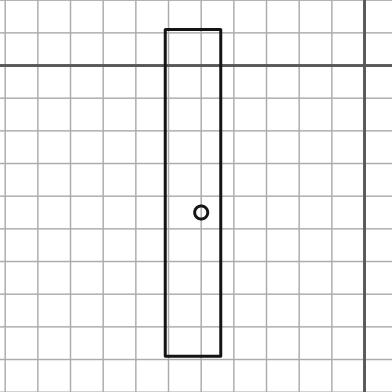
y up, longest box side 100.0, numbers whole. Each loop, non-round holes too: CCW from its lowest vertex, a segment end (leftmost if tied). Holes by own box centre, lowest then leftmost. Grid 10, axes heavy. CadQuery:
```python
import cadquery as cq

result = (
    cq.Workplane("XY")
    .moveTo(-61.0, -89.0)
    .lineTo(-44.0, -89.0)
    .lineTo(-44.0, 11.0)
    .lineTo(-61.0, 11.0)
    .close()
    .moveTo(-50.0, -45.0)
    .circle(2.0)
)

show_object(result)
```